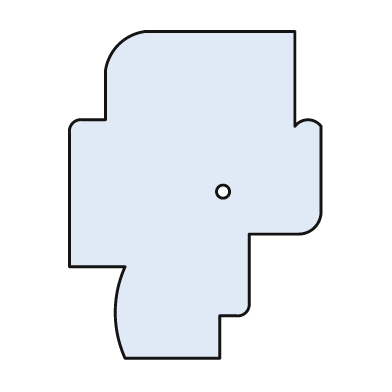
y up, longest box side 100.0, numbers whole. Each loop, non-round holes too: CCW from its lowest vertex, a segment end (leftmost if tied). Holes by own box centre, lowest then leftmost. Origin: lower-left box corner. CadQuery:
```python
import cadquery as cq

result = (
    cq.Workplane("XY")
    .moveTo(17.0, 0.0)
    .lineTo(46.0, 0.0)
    .lineTo(46.0, 13.0)
    .lineTo(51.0, 13.0)
    .threePointArc((54.0, 14.0), (55.0, 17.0))
    .lineTo(55.0, 38.0)
    .lineTo(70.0, 38.0)
    .threePointArc((75.0, 40.0), (77.0, 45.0))
    .lineTo(77.0, 71.0)
    .threePointArc((73.0, 73.0), (69.0, 71.0))
    .lineTo(69.0, 100.0)
    .lineTo(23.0, 100.0)
    .threePointArc((15.0, 96.0), (11.0, 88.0))
    .lineTo(11.0, 73.0)
    .lineTo(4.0, 73.0)
    .threePointArc((1.0, 72.0), (0.0, 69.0))
    .lineTo(0.0, 28.0)
    .lineTo(17.0, 28.0)
    .threePointArc((14.0, 14.0), (17.0, 0.0))
    .close()
    .moveTo(47.0, 51.0)
    .circle(2.0)
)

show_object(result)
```